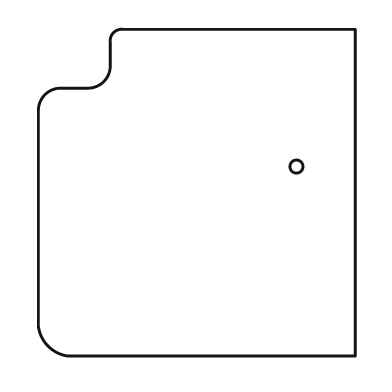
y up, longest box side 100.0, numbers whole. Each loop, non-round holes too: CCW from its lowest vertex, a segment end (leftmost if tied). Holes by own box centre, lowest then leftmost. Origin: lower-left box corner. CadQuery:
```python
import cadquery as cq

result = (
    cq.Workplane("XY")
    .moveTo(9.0, 0.0)
    .lineTo(97.0, 0.0)
    .lineTo(97.0, 100.0)
    .lineTo(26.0, 100.0)
    .threePointArc((23.0, 99.0), (22.0, 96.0))
    .lineTo(22.0, 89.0)
    .threePointArc((20.0, 84.0), (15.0, 82.0))
    .lineTo(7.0, 82.0)
    .threePointArc((2.0, 80.0), (0.0, 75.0))
    .lineTo(0.0, 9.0)
    .threePointArc((3.0, 3.0), (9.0, 0.0))
    .close()
    .moveTo(79.0, 58.0)
    .circle(2.0)
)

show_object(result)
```